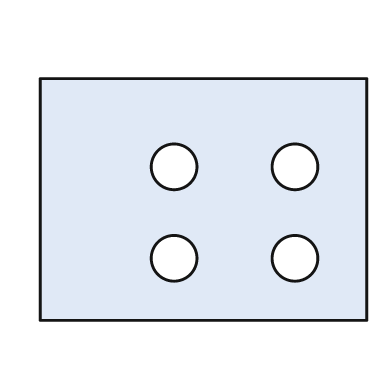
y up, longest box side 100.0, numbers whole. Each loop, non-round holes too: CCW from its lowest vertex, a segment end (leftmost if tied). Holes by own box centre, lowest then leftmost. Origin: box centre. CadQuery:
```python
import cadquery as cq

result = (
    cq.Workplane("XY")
    .moveTo(-50.0, -37.0)
    .lineTo(50.0, -37.0)
    .lineTo(50.0, 37.0)
    .lineTo(-50.0, 37.0)
    .close()
    .moveTo(-9.0, -18.0)
    .circle(7.0)
    .moveTo(28.0, -18.0)
    .circle(7.0)
    .moveTo(-9.0, 10.0)
    .circle(7.0)
    .moveTo(28.0, 10.0)
    .circle(7.0)
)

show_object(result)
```